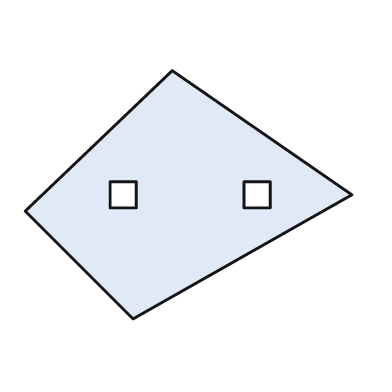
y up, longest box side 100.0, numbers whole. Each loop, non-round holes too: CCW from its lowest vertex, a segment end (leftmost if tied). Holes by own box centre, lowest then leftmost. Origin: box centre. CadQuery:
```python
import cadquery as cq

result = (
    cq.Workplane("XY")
    .moveTo(-17.0, -38.0)
    .lineTo(50.0, 0.0)
    .lineTo(-5.0, 38.0)
    .lineTo(-50.0, -5.0)
    .close()
    .moveTo(-24.0, -4.0)
    .lineTo(-16.0, -4.0)
    .lineTo(-16.0, 4.0)
    .lineTo(-24.0, 4.0)
    .close()
    .moveTo(17.0, -4.0)
    .lineTo(25.0, -4.0)
    .lineTo(25.0, 4.0)
    .lineTo(17.0, 4.0)
    .close()
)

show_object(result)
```